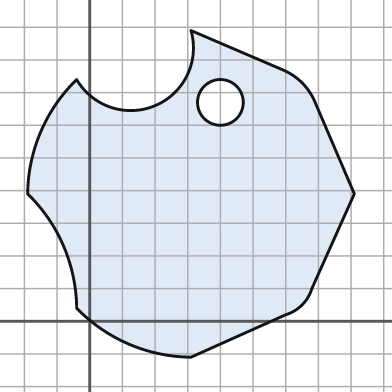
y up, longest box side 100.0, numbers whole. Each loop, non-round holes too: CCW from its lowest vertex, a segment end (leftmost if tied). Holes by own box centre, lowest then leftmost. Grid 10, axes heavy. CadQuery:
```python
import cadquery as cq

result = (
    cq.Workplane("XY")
    .moveTo(31.0, -11.0)
    .lineTo(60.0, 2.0)
    .threePointArc((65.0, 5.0), (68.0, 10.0))
    .lineTo(81.0, 39.0)
    .lineTo(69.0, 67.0)
    .threePointArc((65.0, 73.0), (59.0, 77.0))
    .lineTo(31.0, 89.0)
    .threePointArc((20.0, 66.0), (-4.0, 74.0))
    .threePointArc((-15.0, 58.0), (-19.0, 39.0))
    .threePointArc((-8.0, 23.0), (-4.0, 4.0))
    .threePointArc((12.0, -7.0), (31.0, -11.0))
    .close()
    .moveTo(40.0, 67.0)
    .circle(7.0)
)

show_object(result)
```